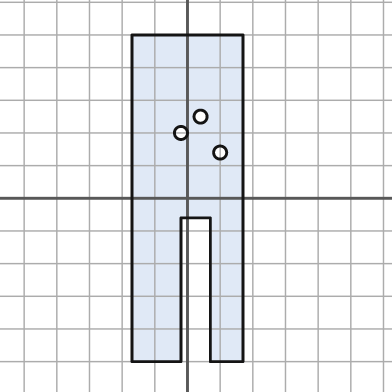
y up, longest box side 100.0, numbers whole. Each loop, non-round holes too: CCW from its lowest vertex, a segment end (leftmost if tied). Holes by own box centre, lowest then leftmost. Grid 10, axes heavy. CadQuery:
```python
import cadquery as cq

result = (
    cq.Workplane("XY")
    .moveTo(-17.0, -50.0)
    .lineTo(-2.0, -50.0)
    .lineTo(-2.0, -6.0)
    .lineTo(7.0, -6.0)
    .lineTo(7.0, -50.0)
    .lineTo(17.0, -50.0)
    .lineTo(17.0, 50.0)
    .lineTo(-17.0, 50.0)
    .close()
    .moveTo(10.0, 14.0)
    .circle(2.0)
    .moveTo(-2.0, 20.0)
    .circle(2.0)
    .moveTo(4.0, 25.0)
    .circle(2.0)
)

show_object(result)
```